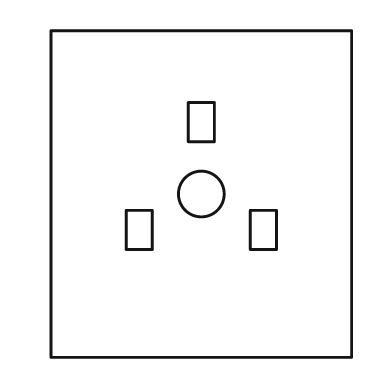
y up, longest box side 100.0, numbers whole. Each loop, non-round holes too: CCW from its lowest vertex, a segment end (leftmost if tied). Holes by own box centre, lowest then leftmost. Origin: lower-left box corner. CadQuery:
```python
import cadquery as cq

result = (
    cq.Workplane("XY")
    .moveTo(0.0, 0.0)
    .lineTo(92.0, 0.0)
    .lineTo(92.0, 100.0)
    .lineTo(0.0, 100.0)
    .close()
    .moveTo(23.0, 33.0)
    .lineTo(31.0, 33.0)
    .lineTo(31.0, 45.0)
    .lineTo(23.0, 45.0)
    .close()
    .moveTo(61.0, 33.0)
    .lineTo(69.0, 33.0)
    .lineTo(69.0, 45.0)
    .lineTo(61.0, 45.0)
    .close()
    .moveTo(46.0, 50.0)
    .circle(7.0)
    .moveTo(42.0, 66.0)
    .lineTo(50.0, 66.0)
    .lineTo(50.0, 78.0)
    .lineTo(42.0, 78.0)
    .close()
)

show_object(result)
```